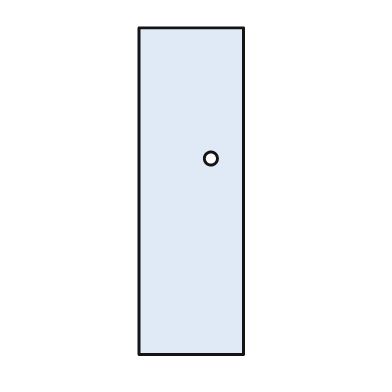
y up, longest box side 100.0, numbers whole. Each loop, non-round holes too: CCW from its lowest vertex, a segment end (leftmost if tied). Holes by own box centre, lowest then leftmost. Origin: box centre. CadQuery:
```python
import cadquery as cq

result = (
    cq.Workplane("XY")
    .moveTo(-16.0, -50.0)
    .lineTo(16.0, -50.0)
    .lineTo(16.0, 50.0)
    .lineTo(-16.0, 50.0)
    .close()
    .moveTo(6.0, 10.0)
    .circle(2.0)
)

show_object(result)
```